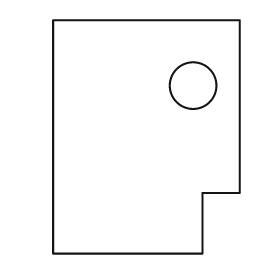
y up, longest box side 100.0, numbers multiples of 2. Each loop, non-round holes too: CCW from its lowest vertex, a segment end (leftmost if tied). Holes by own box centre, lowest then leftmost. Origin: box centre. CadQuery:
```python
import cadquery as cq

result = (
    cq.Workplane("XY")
    .moveTo(-40.0, -50.0)
    .lineTo(24.0, -50.0)
    .lineTo(24.0, -24.0)
    .lineTo(40.0, -24.0)
    .lineTo(40.0, 50.0)
    .lineTo(-40.0, 50.0)
    .close()
    .moveTo(20.0, 22.0)
    .circle(10.0)
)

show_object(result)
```